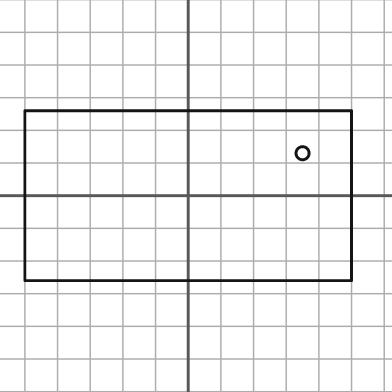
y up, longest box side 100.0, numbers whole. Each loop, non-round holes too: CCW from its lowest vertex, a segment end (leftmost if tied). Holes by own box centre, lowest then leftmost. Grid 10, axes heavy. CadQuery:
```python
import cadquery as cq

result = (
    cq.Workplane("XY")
    .moveTo(-50.0, -26.0)
    .lineTo(50.0, -26.0)
    .lineTo(50.0, 26.0)
    .lineTo(-50.0, 26.0)
    .close()
    .moveTo(35.0, 13.0)
    .circle(2.0)
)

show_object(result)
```